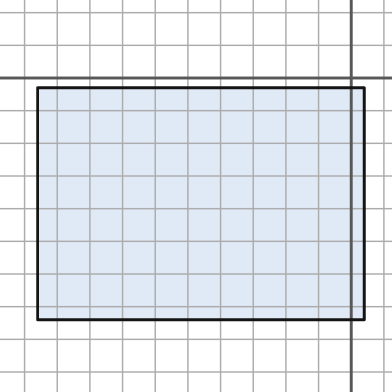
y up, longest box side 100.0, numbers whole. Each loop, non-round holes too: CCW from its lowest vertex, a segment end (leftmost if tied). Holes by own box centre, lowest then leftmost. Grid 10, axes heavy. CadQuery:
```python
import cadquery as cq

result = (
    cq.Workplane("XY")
    .moveTo(-96.0, -74.0)
    .lineTo(4.0, -74.0)
    .lineTo(4.0, -3.0)
    .lineTo(-96.0, -3.0)
    .close()
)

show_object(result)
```